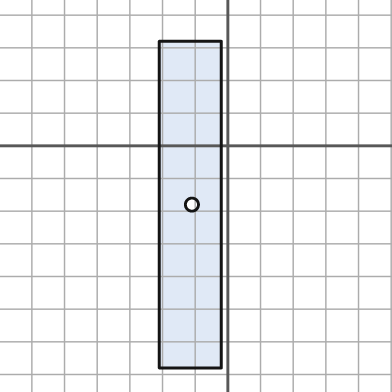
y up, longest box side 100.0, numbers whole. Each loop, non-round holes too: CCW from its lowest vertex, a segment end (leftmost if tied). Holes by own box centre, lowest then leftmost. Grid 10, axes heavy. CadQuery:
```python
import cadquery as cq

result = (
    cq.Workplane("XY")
    .moveTo(-21.0, -68.0)
    .lineTo(-2.0, -68.0)
    .lineTo(-2.0, 32.0)
    .lineTo(-21.0, 32.0)
    .close()
    .moveTo(-11.0, -18.0)
    .circle(2.0)
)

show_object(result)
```